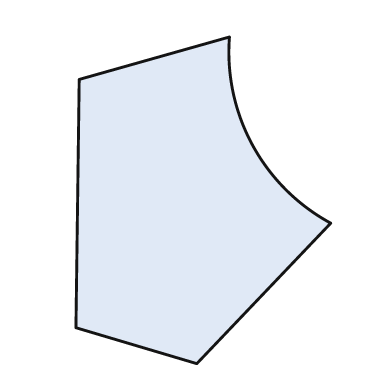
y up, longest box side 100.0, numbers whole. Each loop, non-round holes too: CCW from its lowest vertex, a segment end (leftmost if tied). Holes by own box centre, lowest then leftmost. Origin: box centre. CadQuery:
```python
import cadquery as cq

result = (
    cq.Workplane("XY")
    .moveTo(-2.0, -50.0)
    .lineTo(39.0, -7.0)
    .threePointArc((15.0, 17.0), (8.0, 50.0))
    .lineTo(-38.0, 37.0)
    .lineTo(-39.0, -39.0)
    .close()
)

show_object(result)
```